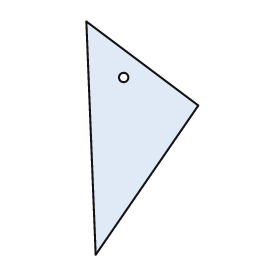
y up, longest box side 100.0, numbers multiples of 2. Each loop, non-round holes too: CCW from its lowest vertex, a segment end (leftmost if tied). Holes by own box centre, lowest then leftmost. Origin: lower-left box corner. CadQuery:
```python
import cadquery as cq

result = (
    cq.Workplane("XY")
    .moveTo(4.0, 0.0)
    .lineTo(48.0, 64.0)
    .lineTo(0.0, 100.0)
    .close()
    .moveTo(16.0, 76.0)
    .circle(2.0)
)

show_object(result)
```